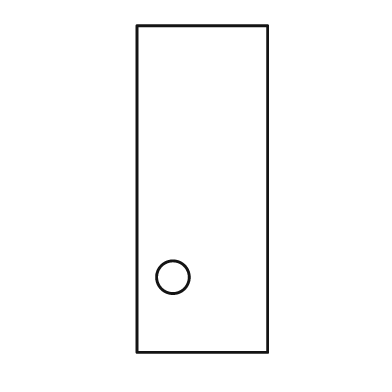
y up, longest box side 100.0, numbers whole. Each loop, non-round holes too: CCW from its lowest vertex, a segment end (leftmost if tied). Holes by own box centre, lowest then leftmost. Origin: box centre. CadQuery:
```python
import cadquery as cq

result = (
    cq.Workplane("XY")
    .moveTo(-20.0, -50.0)
    .lineTo(20.0, -50.0)
    .lineTo(20.0, 50.0)
    .lineTo(-20.0, 50.0)
    .close()
    .moveTo(-9.0, -27.0)
    .circle(5.0)
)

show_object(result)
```